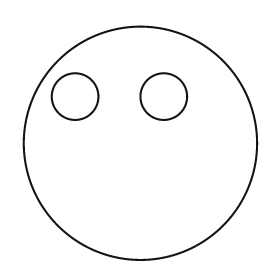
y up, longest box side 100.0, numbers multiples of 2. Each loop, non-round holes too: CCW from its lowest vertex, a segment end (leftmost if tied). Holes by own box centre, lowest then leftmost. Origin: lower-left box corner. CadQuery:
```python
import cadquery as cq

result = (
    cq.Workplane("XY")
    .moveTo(50.0, 50.0)
    .circle(50.0)
    .moveTo(22.0, 70.0)
    .circle(10.0)
    .moveTo(60.0, 70.0)
    .circle(10.0)
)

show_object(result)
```